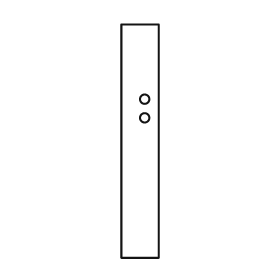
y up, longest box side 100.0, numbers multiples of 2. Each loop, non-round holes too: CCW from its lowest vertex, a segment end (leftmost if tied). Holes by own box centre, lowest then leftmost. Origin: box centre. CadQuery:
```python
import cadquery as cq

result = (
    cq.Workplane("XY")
    .moveTo(-8.0, -50.0)
    .lineTo(8.0, -50.0)
    .lineTo(8.0, 50.0)
    .lineTo(-8.0, 50.0)
    .close()
    .moveTo(2.0, 10.0)
    .circle(2.0)
    .moveTo(2.0, 18.0)
    .circle(2.0)
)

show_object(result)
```